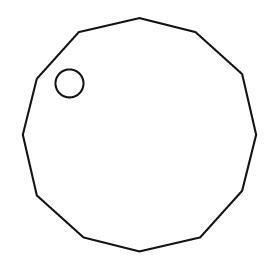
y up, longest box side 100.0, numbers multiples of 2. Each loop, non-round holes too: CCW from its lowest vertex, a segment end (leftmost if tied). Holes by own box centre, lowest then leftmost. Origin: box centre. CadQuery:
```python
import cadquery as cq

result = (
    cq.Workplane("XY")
    .moveTo(0.0, -50.0)
    .lineTo(26.0, -44.0)
    .lineTo(44.0, -24.0)
    .lineTo(50.0, 0.0)
    .lineTo(44.0, 26.0)
    .lineTo(24.0, 44.0)
    .lineTo(0.0, 50.0)
    .lineTo(-26.0, 44.0)
    .lineTo(-44.0, 24.0)
    .lineTo(-50.0, 0.0)
    .lineTo(-44.0, -26.0)
    .lineTo(-24.0, -44.0)
    .close()
    .moveTo(-30.0, 22.0)
    .circle(6.0)
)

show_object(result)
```